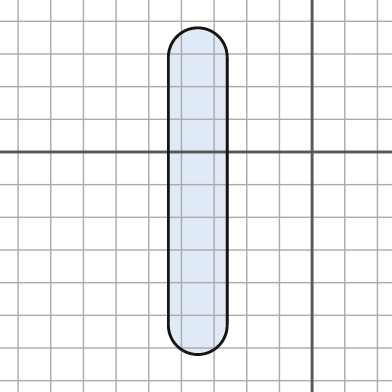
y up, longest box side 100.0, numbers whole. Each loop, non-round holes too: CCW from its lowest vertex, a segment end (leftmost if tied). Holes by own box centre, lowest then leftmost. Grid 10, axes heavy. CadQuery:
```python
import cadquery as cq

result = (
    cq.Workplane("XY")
    .moveTo(-44.0, -53.0)
    .threePointArc((-35.0, -62.0), (-26.0, -53.0))
    .lineTo(-26.0, 29.0)
    .threePointArc((-35.0, 38.0), (-44.0, 29.0))
    .close()
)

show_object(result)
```